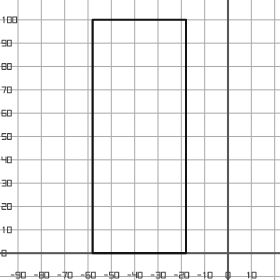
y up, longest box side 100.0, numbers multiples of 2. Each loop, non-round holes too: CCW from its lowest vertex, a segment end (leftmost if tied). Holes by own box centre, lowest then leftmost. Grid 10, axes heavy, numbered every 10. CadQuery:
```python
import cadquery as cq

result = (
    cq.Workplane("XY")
    .moveTo(-58.0, 0.0)
    .lineTo(-18.0, 0.0)
    .lineTo(-18.0, 100.0)
    .lineTo(-58.0, 100.0)
    .close()
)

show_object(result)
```